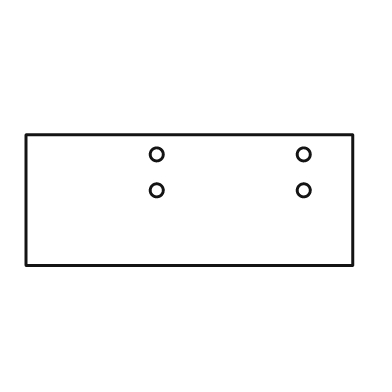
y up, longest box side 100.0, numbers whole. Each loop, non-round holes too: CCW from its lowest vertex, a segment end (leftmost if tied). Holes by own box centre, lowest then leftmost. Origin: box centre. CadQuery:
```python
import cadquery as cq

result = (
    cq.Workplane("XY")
    .moveTo(-50.0, -20.0)
    .lineTo(50.0, -20.0)
    .lineTo(50.0, 20.0)
    .lineTo(-50.0, 20.0)
    .close()
    .moveTo(-10.0, 3.0)
    .circle(2.0)
    .moveTo(35.0, 3.0)
    .circle(2.0)
    .moveTo(-10.0, 14.0)
    .circle(2.0)
    .moveTo(35.0, 14.0)
    .circle(2.0)
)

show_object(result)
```